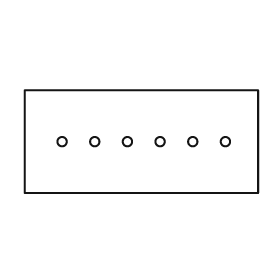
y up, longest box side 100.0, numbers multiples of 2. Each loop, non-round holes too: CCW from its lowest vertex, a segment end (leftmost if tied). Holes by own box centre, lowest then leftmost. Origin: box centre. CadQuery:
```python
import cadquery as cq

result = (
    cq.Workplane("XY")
    .moveTo(-50.0, -22.0)
    .lineTo(50.0, -22.0)
    .lineTo(50.0, 22.0)
    .lineTo(-50.0, 22.0)
    .close()
    .moveTo(-34.0, 0.0)
    .circle(2.0)
    .moveTo(-20.0, 0.0)
    .circle(2.0)
    .moveTo(-6.0, 0.0)
    .circle(2.0)
    .moveTo(8.0, 0.0)
    .circle(2.0)
    .moveTo(22.0, 0.0)
    .circle(2.0)
    .moveTo(36.0, 0.0)
    .circle(2.0)
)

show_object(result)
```